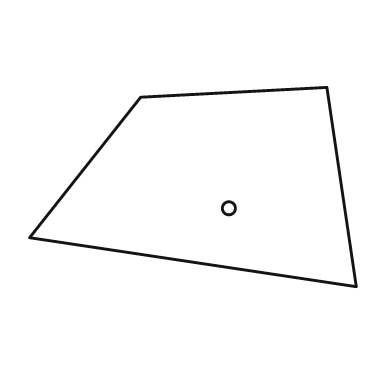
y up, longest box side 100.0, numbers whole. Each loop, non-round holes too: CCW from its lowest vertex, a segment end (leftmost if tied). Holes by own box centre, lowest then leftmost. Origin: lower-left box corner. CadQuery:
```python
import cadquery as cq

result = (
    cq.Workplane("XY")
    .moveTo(100.0, 0.0)
    .lineTo(91.0, 61.0)
    .lineTo(34.0, 58.0)
    .lineTo(0.0, 15.0)
    .close()
    .moveTo(61.0, 24.0)
    .circle(2.0)
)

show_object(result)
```